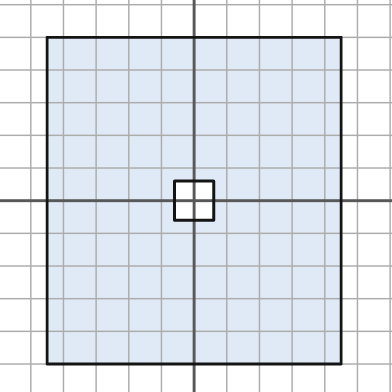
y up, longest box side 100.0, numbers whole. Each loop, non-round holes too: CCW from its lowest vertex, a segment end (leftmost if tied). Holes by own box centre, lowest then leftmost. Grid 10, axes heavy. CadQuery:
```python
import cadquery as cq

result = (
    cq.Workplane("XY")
    .moveTo(-45.0, -50.0)
    .lineTo(45.0, -50.0)
    .lineTo(45.0, 50.0)
    .lineTo(-45.0, 50.0)
    .close()
    .moveTo(-6.0, -6.0)
    .lineTo(6.0, -6.0)
    .lineTo(6.0, 6.0)
    .lineTo(-6.0, 6.0)
    .close()
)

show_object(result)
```